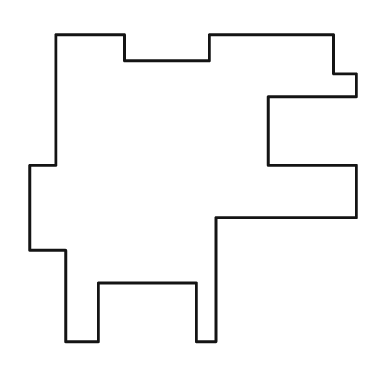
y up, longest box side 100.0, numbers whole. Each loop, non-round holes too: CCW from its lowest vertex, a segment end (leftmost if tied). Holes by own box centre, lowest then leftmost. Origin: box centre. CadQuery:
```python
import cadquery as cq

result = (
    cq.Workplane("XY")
    .moveTo(-39.0, -47.0)
    .lineTo(-29.0, -47.0)
    .lineTo(-29.0, -29.0)
    .lineTo(1.0, -29.0)
    .lineTo(1.0, -47.0)
    .lineTo(7.0, -47.0)
    .lineTo(7.0, -9.0)
    .lineTo(50.0, -9.0)
    .lineTo(50.0, 7.0)
    .lineTo(23.0, 7.0)
    .lineTo(23.0, 28.0)
    .lineTo(50.0, 28.0)
    .lineTo(50.0, 35.0)
    .lineTo(43.0, 35.0)
    .lineTo(43.0, 47.0)
    .lineTo(5.0, 47.0)
    .lineTo(5.0, 39.0)
    .lineTo(-21.0, 39.0)
    .lineTo(-21.0, 47.0)
    .lineTo(-42.0, 47.0)
    .lineTo(-42.0, 7.0)
    .lineTo(-50.0, 7.0)
    .lineTo(-50.0, -19.0)
    .lineTo(-39.0, -19.0)
    .close()
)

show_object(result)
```